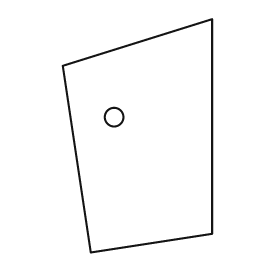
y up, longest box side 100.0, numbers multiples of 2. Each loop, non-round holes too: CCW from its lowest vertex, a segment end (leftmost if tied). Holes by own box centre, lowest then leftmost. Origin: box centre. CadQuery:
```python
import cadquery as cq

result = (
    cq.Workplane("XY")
    .moveTo(-20.0, -50.0)
    .lineTo(32.0, -42.0)
    .lineTo(32.0, 50.0)
    .lineTo(-32.0, 30.0)
    .close()
    .moveTo(-10.0, 8.0)
    .circle(4.0)
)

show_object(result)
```